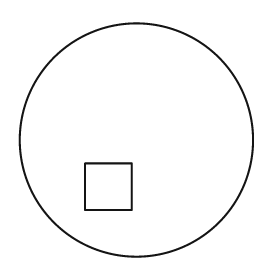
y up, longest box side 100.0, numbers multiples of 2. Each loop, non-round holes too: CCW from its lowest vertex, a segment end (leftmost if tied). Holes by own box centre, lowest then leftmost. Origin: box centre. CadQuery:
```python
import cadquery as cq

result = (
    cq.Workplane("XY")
    .moveTo(0.0, 0.0)
    .circle(50.0)
    .moveTo(-22.0, -30.0)
    .lineTo(-2.0, -30.0)
    .lineTo(-2.0, -10.0)
    .lineTo(-22.0, -10.0)
    .close()
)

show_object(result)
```